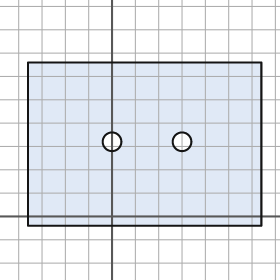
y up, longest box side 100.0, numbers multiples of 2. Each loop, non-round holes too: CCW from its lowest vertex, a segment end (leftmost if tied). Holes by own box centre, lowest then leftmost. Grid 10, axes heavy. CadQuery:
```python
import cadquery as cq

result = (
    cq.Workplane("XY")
    .moveTo(-36.0, -4.0)
    .lineTo(64.0, -4.0)
    .lineTo(64.0, 66.0)
    .lineTo(-36.0, 66.0)
    .close()
    .moveTo(0.0, 32.0)
    .circle(4.0)
    .moveTo(30.0, 32.0)
    .circle(4.0)
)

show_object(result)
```